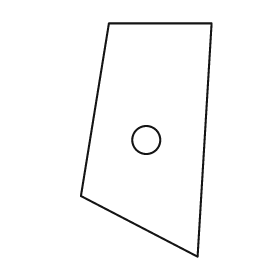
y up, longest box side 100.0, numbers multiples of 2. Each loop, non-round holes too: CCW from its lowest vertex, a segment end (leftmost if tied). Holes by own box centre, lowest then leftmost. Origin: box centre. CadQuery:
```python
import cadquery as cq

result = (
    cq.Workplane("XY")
    .moveTo(22.0, -50.0)
    .lineTo(28.0, 50.0)
    .lineTo(-16.0, 50.0)
    .lineTo(-28.0, -24.0)
    .close()
    .moveTo(0.0, 0.0)
    .circle(6.0)
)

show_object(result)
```